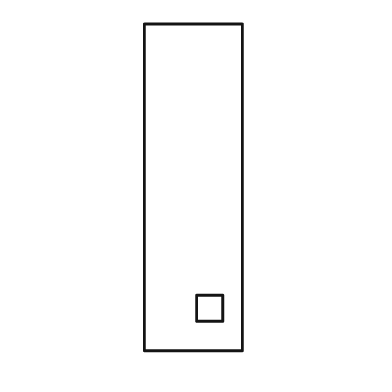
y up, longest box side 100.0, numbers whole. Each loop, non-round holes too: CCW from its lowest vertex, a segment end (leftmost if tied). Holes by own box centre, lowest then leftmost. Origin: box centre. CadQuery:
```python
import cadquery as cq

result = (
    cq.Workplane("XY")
    .moveTo(-15.0, -50.0)
    .lineTo(15.0, -50.0)
    .lineTo(15.0, 50.0)
    .lineTo(-15.0, 50.0)
    .close()
    .moveTo(1.0, -41.0)
    .lineTo(9.0, -41.0)
    .lineTo(9.0, -33.0)
    .lineTo(1.0, -33.0)
    .close()
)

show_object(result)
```